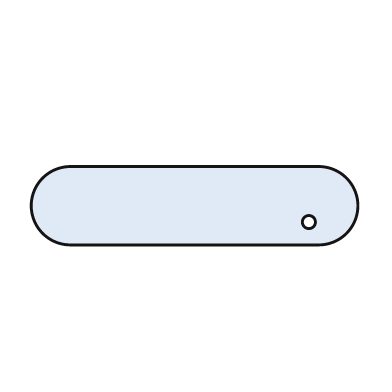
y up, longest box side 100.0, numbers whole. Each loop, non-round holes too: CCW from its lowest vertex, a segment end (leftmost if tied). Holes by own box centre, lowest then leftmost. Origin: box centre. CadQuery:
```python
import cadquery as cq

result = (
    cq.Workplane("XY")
    .moveTo(-38.0, -12.0)
    .lineTo(38.0, -12.0)
    .threePointArc((50.0, 0.0), (38.0, 12.0))
    .lineTo(-38.0, 12.0)
    .threePointArc((-50.0, 0.0), (-38.0, -12.0))
    .close()
    .moveTo(35.0, -5.0)
    .circle(2.0)
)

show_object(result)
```